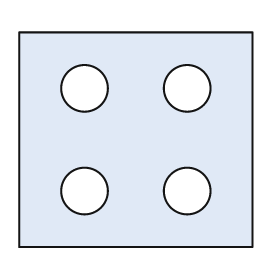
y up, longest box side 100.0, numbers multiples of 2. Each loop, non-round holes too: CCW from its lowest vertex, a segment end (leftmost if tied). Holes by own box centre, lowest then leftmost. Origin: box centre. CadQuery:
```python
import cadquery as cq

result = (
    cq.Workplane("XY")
    .moveTo(-50.0, -46.0)
    .lineTo(50.0, -46.0)
    .lineTo(50.0, 46.0)
    .lineTo(-50.0, 46.0)
    .close()
    .moveTo(-22.0, -22.0)
    .circle(10.0)
    .moveTo(22.0, -22.0)
    .circle(10.0)
    .moveTo(-22.0, 22.0)
    .circle(10.0)
    .moveTo(22.0, 22.0)
    .circle(10.0)
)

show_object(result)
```